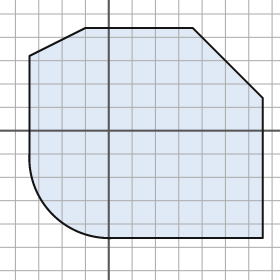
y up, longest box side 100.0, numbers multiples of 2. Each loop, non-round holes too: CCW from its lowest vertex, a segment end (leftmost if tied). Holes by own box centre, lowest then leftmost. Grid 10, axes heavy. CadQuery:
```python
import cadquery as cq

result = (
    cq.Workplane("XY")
    .moveTo(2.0, -46.0)
    .lineTo(66.0, -46.0)
    .lineTo(66.0, 14.0)
    .lineTo(36.0, 44.0)
    .lineTo(-10.0, 44.0)
    .lineTo(-34.0, 32.0)
    .lineTo(-34.0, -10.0)
    .threePointArc((-24.0, -36.0), (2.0, -46.0))
    .close()
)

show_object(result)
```